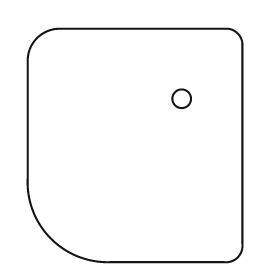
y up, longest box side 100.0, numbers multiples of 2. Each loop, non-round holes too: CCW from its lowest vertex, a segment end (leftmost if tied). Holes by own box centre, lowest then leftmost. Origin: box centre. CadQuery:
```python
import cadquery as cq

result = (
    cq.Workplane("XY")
    .moveTo(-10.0, -50.0)
    .lineTo(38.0, -50.0)
    .threePointArc((44.0, -48.0), (46.0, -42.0))
    .lineTo(46.0, 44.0)
    .threePointArc((44.0, 48.0), (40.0, 50.0))
    .lineTo(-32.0, 50.0)
    .threePointArc((-42.0, 46.0), (-46.0, 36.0))
    .lineTo(-46.0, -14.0)
    .threePointArc((-36.0, -40.0), (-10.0, -50.0))
    .close()
    .moveTo(20.0, 20.0)
    .circle(4.0)
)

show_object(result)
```